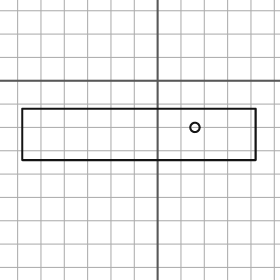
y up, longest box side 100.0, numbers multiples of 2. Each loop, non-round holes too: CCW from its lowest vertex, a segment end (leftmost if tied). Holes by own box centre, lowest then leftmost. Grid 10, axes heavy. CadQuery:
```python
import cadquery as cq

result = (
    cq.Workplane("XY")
    .moveTo(-58.0, -34.0)
    .lineTo(42.0, -34.0)
    .lineTo(42.0, -12.0)
    .lineTo(-58.0, -12.0)
    .close()
    .moveTo(16.0, -20.0)
    .circle(2.0)
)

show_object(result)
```